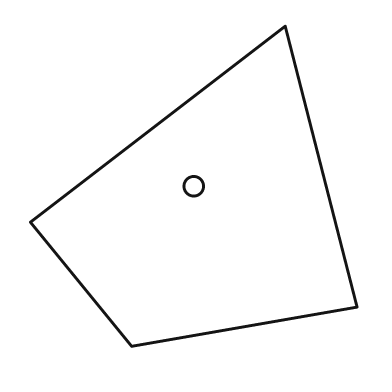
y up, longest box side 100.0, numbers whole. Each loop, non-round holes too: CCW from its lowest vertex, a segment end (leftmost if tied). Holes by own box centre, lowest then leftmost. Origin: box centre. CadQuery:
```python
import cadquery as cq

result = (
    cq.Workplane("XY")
    .moveTo(-19.0, -49.0)
    .lineTo(50.0, -37.0)
    .lineTo(28.0, 49.0)
    .lineTo(-50.0, -11.0)
    .close()
    .moveTo(0.0, 0.0)
    .circle(3.0)
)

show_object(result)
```